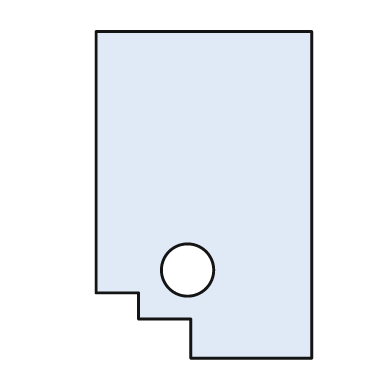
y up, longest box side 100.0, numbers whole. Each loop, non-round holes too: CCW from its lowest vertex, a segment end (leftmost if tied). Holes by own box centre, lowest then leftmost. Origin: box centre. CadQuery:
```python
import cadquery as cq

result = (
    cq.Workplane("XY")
    .moveTo(-4.0, -50.0)
    .lineTo(33.0, -50.0)
    .lineTo(33.0, 50.0)
    .lineTo(-33.0, 50.0)
    .lineTo(-33.0, -30.0)
    .lineTo(-20.0, -30.0)
    .lineTo(-20.0, -38.0)
    .lineTo(-4.0, -38.0)
    .close()
    .moveTo(-5.0, -23.0)
    .circle(8.0)
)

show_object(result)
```